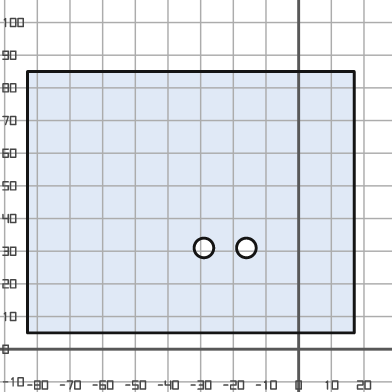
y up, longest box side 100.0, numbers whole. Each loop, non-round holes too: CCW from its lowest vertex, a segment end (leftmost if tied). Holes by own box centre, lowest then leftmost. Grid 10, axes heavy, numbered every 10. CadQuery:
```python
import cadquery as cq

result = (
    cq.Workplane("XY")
    .moveTo(-83.0, 5.0)
    .lineTo(17.0, 5.0)
    .lineTo(17.0, 85.0)
    .lineTo(-83.0, 85.0)
    .close()
    .moveTo(-29.0, 31.0)
    .circle(3.0)
    .moveTo(-16.0, 31.0)
    .circle(3.0)
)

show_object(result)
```